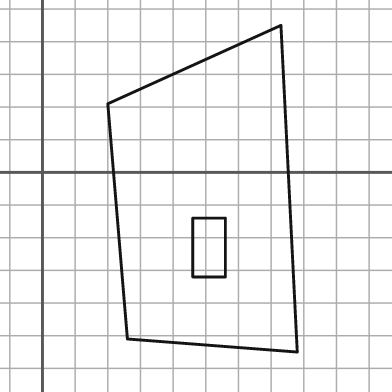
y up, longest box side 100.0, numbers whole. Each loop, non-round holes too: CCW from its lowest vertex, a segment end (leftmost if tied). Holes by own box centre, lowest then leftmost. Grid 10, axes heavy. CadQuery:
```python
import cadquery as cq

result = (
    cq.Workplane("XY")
    .moveTo(78.0, -55.0)
    .lineTo(73.0, 45.0)
    .lineTo(20.0, 21.0)
    .lineTo(26.0, -51.0)
    .close()
    .moveTo(46.0, -32.0)
    .lineTo(56.0, -32.0)
    .lineTo(56.0, -14.0)
    .lineTo(46.0, -14.0)
    .close()
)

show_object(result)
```